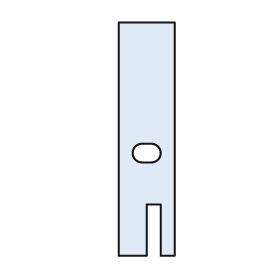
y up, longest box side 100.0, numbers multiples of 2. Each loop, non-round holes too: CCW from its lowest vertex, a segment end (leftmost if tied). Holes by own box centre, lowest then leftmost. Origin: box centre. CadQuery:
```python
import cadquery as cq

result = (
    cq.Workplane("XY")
    .moveTo(-12.0, -50.0)
    .lineTo(0.0, -50.0)
    .lineTo(0.0, -28.0)
    .lineTo(6.0, -28.0)
    .lineTo(6.0, -50.0)
    .lineTo(12.0, -50.0)
    .lineTo(12.0, 50.0)
    .lineTo(-12.0, 50.0)
    .close()
    .moveTo(-2.0, -10.0)
    .lineTo(2.0, -10.0)
    .threePointArc((6.0, -6.0), (2.0, -2.0))
    .lineTo(-2.0, -2.0)
    .threePointArc((-6.0, -6.0), (-2.0, -10.0))
    .close()
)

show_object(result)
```